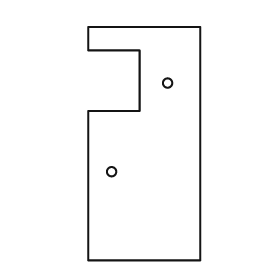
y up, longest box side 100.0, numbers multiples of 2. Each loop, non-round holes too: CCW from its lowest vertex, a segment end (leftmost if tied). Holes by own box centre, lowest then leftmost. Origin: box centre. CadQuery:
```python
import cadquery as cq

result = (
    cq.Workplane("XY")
    .moveTo(-24.0, -50.0)
    .lineTo(24.0, -50.0)
    .lineTo(24.0, 50.0)
    .lineTo(-24.0, 50.0)
    .lineTo(-24.0, 40.0)
    .lineTo(-2.0, 40.0)
    .lineTo(-2.0, 14.0)
    .lineTo(-24.0, 14.0)
    .close()
    .moveTo(-14.0, -12.0)
    .circle(2.0)
    .moveTo(10.0, 26.0)
    .circle(2.0)
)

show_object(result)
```